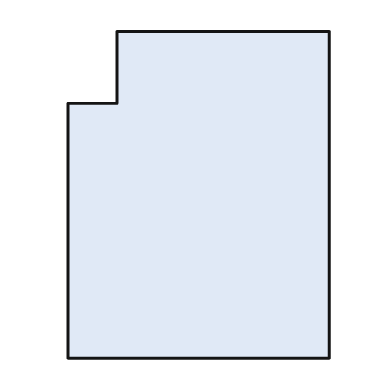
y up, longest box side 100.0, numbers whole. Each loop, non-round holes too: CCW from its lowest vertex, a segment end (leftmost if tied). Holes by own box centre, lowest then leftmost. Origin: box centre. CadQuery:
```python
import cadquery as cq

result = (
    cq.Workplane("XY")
    .moveTo(-40.0, -50.0)
    .lineTo(40.0, -50.0)
    .lineTo(40.0, 50.0)
    .lineTo(-25.0, 50.0)
    .lineTo(-25.0, 28.0)
    .lineTo(-40.0, 28.0)
    .close()
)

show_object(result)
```